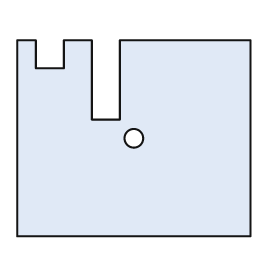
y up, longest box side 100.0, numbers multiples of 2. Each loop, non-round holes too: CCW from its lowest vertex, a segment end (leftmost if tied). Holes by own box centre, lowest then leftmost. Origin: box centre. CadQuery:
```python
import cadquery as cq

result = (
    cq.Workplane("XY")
    .moveTo(-50.0, -42.0)
    .lineTo(50.0, -42.0)
    .lineTo(50.0, 42.0)
    .lineTo(-6.0, 42.0)
    .lineTo(-6.0, 8.0)
    .lineTo(-18.0, 8.0)
    .lineTo(-18.0, 42.0)
    .lineTo(-30.0, 42.0)
    .lineTo(-30.0, 30.0)
    .lineTo(-42.0, 30.0)
    .lineTo(-42.0, 42.0)
    .lineTo(-50.0, 42.0)
    .close()
    .moveTo(0.0, 0.0)
    .circle(4.0)
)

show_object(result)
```